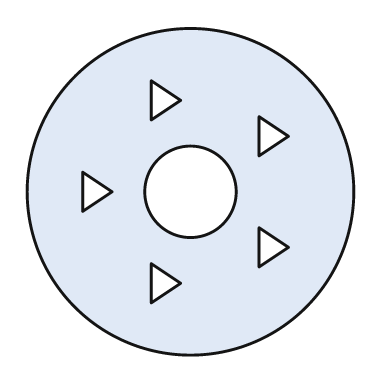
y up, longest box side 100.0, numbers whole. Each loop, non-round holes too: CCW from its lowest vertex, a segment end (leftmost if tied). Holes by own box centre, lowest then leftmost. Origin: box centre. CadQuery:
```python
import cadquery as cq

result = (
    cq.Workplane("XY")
    .moveTo(0.0, 0.0)
    .circle(50.0)
    .moveTo(-12.0, -34.0)
    .lineTo(-3.0, -28.0)
    .lineTo(-12.0, -22.0)
    .close()
    .moveTo(21.0, -23.0)
    .lineTo(30.0, -17.0)
    .lineTo(21.0, -11.0)
    .close()
    .moveTo(-33.0, -6.0)
    .lineTo(-24.0, 0.0)
    .lineTo(-33.0, 6.0)
    .close()
    .moveTo(0.0, 0.0)
    .circle(14.0)
    .moveTo(21.0, 11.0)
    .lineTo(30.0, 17.0)
    .lineTo(21.0, 23.0)
    .close()
    .moveTo(-12.0, 22.0)
    .lineTo(-3.0, 28.0)
    .lineTo(-12.0, 34.0)
    .close()
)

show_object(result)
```